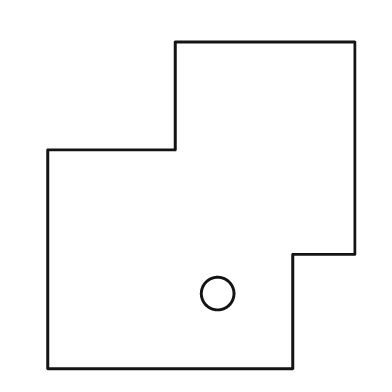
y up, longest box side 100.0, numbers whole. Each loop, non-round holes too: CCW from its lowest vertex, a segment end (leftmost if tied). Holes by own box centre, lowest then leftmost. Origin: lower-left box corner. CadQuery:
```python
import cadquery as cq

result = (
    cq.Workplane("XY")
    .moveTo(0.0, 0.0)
    .lineTo(75.0, 0.0)
    .lineTo(75.0, 35.0)
    .lineTo(94.0, 35.0)
    .lineTo(94.0, 100.0)
    .lineTo(39.0, 100.0)
    .lineTo(39.0, 67.0)
    .lineTo(0.0, 67.0)
    .close()
    .moveTo(52.0, 23.0)
    .circle(5.0)
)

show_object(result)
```